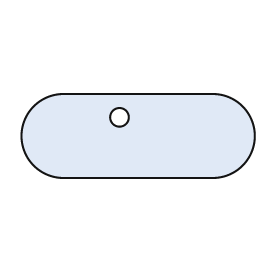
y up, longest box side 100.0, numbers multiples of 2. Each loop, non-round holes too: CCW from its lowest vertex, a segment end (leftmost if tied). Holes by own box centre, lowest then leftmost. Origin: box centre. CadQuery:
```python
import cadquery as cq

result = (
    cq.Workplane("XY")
    .moveTo(-32.0, -18.0)
    .lineTo(32.0, -18.0)
    .threePointArc((50.0, 0.0), (32.0, 18.0))
    .lineTo(-32.0, 18.0)
    .threePointArc((-50.0, 0.0), (-32.0, -18.0))
    .close()
    .moveTo(-8.0, 8.0)
    .circle(4.0)
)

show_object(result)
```